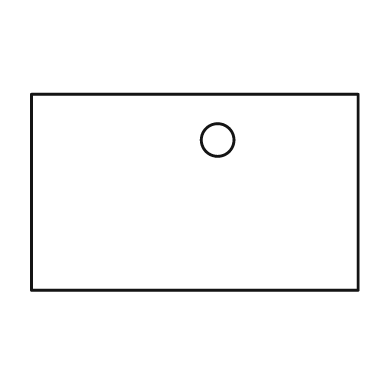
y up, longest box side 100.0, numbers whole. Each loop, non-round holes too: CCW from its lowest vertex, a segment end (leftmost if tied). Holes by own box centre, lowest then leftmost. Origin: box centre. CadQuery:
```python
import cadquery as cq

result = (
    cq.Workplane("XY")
    .moveTo(-50.0, -30.0)
    .lineTo(50.0, -30.0)
    .lineTo(50.0, 30.0)
    .lineTo(-50.0, 30.0)
    .close()
    .moveTo(7.0, 16.0)
    .circle(5.0)
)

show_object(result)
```